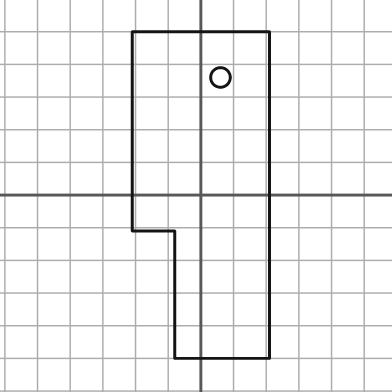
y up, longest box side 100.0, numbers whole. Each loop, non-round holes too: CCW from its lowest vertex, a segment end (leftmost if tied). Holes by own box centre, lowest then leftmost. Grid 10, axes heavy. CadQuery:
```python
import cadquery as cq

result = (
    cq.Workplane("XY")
    .moveTo(-8.0, -50.0)
    .lineTo(21.0, -50.0)
    .lineTo(21.0, 50.0)
    .lineTo(-21.0, 50.0)
    .lineTo(-21.0, -11.0)
    .lineTo(-8.0, -11.0)
    .close()
    .moveTo(6.0, 36.0)
    .circle(3.0)
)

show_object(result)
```